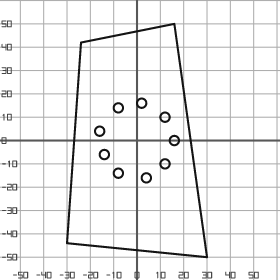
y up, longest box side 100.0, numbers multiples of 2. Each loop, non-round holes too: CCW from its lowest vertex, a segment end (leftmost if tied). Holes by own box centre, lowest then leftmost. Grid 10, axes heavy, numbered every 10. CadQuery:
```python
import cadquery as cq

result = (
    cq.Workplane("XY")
    .moveTo(30.0, -50.0)
    .lineTo(16.0, 50.0)
    .lineTo(-24.0, 42.0)
    .lineTo(-30.0, -44.0)
    .close()
    .moveTo(4.0, -16.0)
    .circle(2.0)
    .moveTo(-8.0, -14.0)
    .circle(2.0)
    .moveTo(12.0, -10.0)
    .circle(2.0)
    .moveTo(-14.0, -6.0)
    .circle(2.0)
    .moveTo(16.0, 0.0)
    .circle(2.0)
    .moveTo(-16.0, 4.0)
    .circle(2.0)
    .moveTo(12.0, 10.0)
    .circle(2.0)
    .moveTo(-8.0, 14.0)
    .circle(2.0)
    .moveTo(2.0, 16.0)
    .circle(2.0)
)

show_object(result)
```